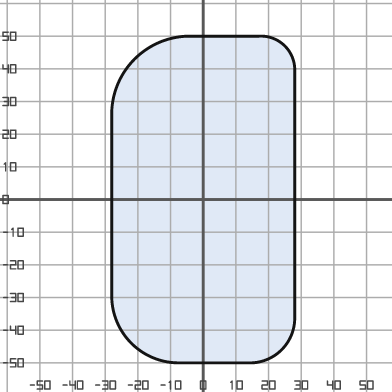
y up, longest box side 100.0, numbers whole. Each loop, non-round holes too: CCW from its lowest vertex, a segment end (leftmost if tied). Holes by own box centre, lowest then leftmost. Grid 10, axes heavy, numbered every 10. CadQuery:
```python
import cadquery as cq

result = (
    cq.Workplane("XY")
    .moveTo(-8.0, -50.0)
    .lineTo(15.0, -50.0)
    .threePointArc((24.0, -46.0), (28.0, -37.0))
    .lineTo(28.0, 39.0)
    .threePointArc((25.0, 47.0), (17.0, 50.0))
    .lineTo(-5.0, 50.0)
    .threePointArc((-21.0, 43.0), (-28.0, 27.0))
    .lineTo(-28.0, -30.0)
    .threePointArc((-22.0, -44.0), (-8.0, -50.0))
    .close()
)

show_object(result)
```